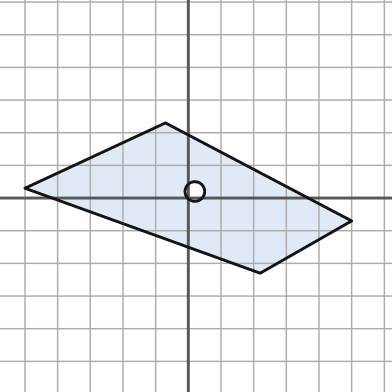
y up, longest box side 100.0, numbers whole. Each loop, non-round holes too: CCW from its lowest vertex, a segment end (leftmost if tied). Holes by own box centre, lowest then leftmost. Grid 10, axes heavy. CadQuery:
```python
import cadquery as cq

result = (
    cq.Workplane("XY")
    .moveTo(22.0, -23.0)
    .lineTo(50.0, -7.0)
    .lineTo(-7.0, 23.0)
    .lineTo(-50.0, 3.0)
    .close()
    .moveTo(2.0, 2.0)
    .circle(3.0)
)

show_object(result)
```